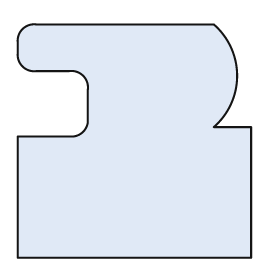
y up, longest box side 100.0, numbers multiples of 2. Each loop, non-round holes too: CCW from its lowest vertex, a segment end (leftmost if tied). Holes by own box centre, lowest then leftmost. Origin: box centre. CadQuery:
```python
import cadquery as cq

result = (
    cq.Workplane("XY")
    .moveTo(-50.0, -50.0)
    .lineTo(50.0, -50.0)
    .lineTo(50.0, 6.0)
    .lineTo(34.0, 6.0)
    .threePointArc((44.0, 28.0), (34.0, 50.0))
    .lineTo(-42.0, 50.0)
    .threePointArc((-48.0, 48.0), (-50.0, 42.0))
    .lineTo(-50.0, 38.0)
    .threePointArc((-48.0, 32.0), (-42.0, 30.0))
    .lineTo(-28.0, 30.0)
    .threePointArc((-22.0, 28.0), (-20.0, 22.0))
    .lineTo(-20.0, 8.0)
    .threePointArc((-22.0, 4.0), (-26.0, 2.0))
    .lineTo(-50.0, 2.0)
    .close()
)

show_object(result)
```